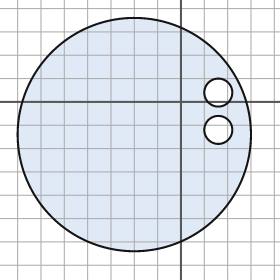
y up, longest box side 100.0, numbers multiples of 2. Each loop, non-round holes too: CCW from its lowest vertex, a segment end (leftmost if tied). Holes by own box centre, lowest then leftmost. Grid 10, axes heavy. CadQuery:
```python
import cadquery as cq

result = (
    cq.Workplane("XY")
    .moveTo(-20.0, -14.0)
    .circle(50.0)
    .moveTo(16.0, -12.0)
    .circle(6.0)
    .moveTo(16.0, 4.0)
    .circle(6.0)
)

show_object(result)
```